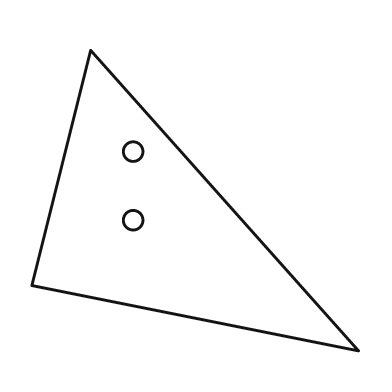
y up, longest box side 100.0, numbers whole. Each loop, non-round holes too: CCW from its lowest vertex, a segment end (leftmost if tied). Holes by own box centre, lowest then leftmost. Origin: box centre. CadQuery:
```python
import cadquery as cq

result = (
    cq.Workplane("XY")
    .moveTo(50.0, -46.0)
    .lineTo(-32.0, 46.0)
    .lineTo(-50.0, -26.0)
    .close()
    .moveTo(-19.0, -6.0)
    .circle(3.0)
    .moveTo(-19.0, 15.0)
    .circle(3.0)
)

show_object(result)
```